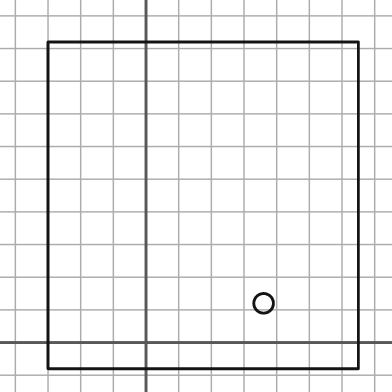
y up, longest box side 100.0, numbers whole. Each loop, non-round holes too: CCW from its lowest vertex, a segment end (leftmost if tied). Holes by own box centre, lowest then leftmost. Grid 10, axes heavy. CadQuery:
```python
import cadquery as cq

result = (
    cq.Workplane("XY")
    .moveTo(-30.0, -8.0)
    .lineTo(65.0, -8.0)
    .lineTo(65.0, 92.0)
    .lineTo(-30.0, 92.0)
    .close()
    .moveTo(36.0, 12.0)
    .circle(3.0)
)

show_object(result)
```